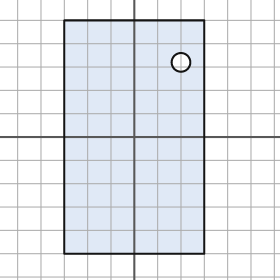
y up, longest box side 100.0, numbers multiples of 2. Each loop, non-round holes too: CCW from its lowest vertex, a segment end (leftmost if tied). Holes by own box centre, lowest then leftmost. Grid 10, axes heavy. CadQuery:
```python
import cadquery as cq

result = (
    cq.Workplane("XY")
    .moveTo(-30.0, -50.0)
    .lineTo(30.0, -50.0)
    .lineTo(30.0, 50.0)
    .lineTo(-30.0, 50.0)
    .close()
    .moveTo(20.0, 32.0)
    .circle(4.0)
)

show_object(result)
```